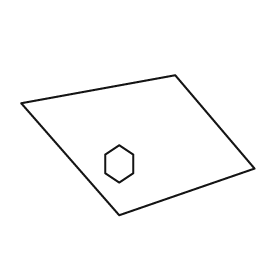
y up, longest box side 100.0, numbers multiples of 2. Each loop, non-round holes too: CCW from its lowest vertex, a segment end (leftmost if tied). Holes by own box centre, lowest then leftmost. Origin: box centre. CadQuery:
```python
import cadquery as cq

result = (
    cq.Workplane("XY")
    .moveTo(-8.0, -30.0)
    .lineTo(50.0, -10.0)
    .lineTo(16.0, 30.0)
    .lineTo(-50.0, 18.0)
    .close()
    .moveTo(-8.0, -16.0)
    .lineTo(-2.0, -12.0)
    .lineTo(-2.0, -4.0)
    .lineTo(-8.0, 0.0)
    .lineTo(-14.0, -4.0)
    .lineTo(-14.0, -12.0)
    .close()
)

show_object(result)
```